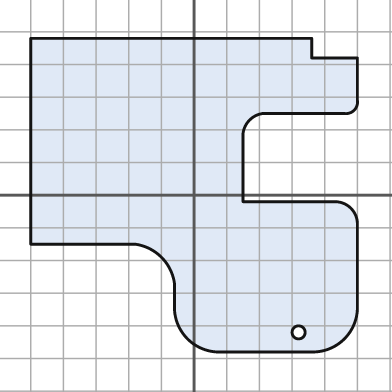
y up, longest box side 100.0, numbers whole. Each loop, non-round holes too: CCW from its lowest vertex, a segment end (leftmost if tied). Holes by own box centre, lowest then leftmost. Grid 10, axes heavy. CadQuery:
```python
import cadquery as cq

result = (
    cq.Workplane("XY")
    .moveTo(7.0, -48.0)
    .lineTo(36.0, -48.0)
    .threePointArc((46.0, -44.0), (50.0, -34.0))
    .lineTo(50.0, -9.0)
    .threePointArc((48.0, -4.0), (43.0, -2.0))
    .lineTo(15.0, -2.0)
    .lineTo(15.0, 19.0)
    .threePointArc((17.0, 23.0), (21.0, 25.0))
    .lineTo(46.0, 25.0)
    .threePointArc((49.0, 26.0), (50.0, 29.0))
    .lineTo(50.0, 42.0)
    .lineTo(36.0, 42.0)
    .lineTo(36.0, 48.0)
    .lineTo(-50.0, 48.0)
    .lineTo(-50.0, -15.0)
    .lineTo(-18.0, -15.0)
    .threePointArc((-10.0, -19.0), (-6.0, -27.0))
    .lineTo(-6.0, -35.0)
    .threePointArc((-2.0, -44.0), (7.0, -48.0))
    .close()
    .moveTo(32.0, -42.0)
    .circle(2.0)
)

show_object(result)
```